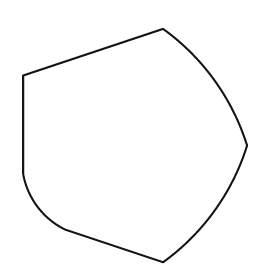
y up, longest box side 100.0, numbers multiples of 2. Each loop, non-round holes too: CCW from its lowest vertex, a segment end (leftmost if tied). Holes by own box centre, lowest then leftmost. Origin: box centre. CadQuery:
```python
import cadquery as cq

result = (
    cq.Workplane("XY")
    .moveTo(12.0, -50.0)
    .threePointArc((34.0, -28.0), (48.0, 0.0))
    .threePointArc((34.0, 28.0), (12.0, 50.0))
    .lineTo(-48.0, 30.0)
    .lineTo(-48.0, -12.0)
    .threePointArc((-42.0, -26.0), (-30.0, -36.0))
    .close()
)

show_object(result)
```